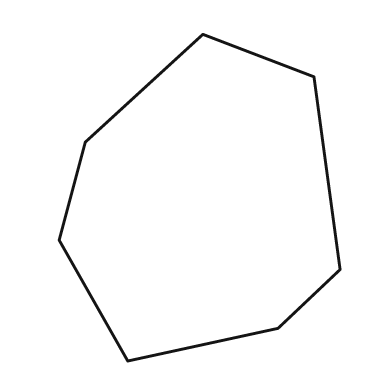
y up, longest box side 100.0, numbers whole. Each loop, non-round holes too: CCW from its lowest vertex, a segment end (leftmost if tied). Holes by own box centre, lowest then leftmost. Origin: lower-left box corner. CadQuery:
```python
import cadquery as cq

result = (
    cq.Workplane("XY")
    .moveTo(21.0, 0.0)
    .lineTo(67.0, 10.0)
    .lineTo(86.0, 28.0)
    .lineTo(78.0, 87.0)
    .lineTo(44.0, 100.0)
    .lineTo(8.0, 67.0)
    .lineTo(0.0, 37.0)
    .close()
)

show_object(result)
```